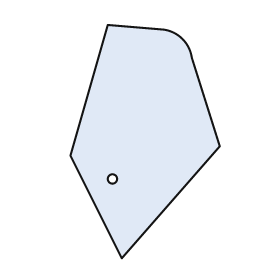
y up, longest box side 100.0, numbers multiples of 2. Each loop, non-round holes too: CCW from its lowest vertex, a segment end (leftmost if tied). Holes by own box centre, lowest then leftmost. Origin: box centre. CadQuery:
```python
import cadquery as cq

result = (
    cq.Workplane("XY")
    .moveTo(-10.0, -50.0)
    .lineTo(32.0, -2.0)
    .lineTo(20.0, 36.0)
    .threePointArc((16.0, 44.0), (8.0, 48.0))
    .lineTo(-16.0, 50.0)
    .lineTo(-32.0, -6.0)
    .close()
    .moveTo(-14.0, -16.0)
    .circle(2.0)
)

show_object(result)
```